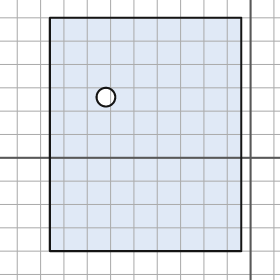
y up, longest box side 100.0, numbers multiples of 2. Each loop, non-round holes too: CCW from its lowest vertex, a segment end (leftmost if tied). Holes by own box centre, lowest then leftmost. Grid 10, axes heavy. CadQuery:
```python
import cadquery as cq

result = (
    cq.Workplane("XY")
    .moveTo(-86.0, -40.0)
    .lineTo(-4.0, -40.0)
    .lineTo(-4.0, 60.0)
    .lineTo(-86.0, 60.0)
    .close()
    .moveTo(-62.0, 26.0)
    .circle(4.0)
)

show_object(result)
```